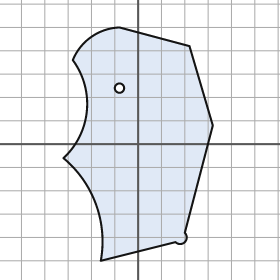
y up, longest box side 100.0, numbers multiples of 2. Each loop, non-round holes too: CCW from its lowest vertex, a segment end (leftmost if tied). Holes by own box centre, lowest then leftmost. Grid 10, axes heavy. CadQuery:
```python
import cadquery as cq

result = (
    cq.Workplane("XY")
    .moveTo(-16.0, -50.0)
    .lineTo(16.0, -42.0)
    .threePointArc((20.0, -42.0), (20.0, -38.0))
    .lineTo(32.0, 8.0)
    .lineTo(22.0, 42.0)
    .lineTo(-8.0, 50.0)
    .threePointArc((-20.0, 46.0), (-28.0, 36.0))
    .threePointArc((-22.0, 14.0), (-32.0, -6.0))
    .threePointArc((-18.0, -26.0), (-16.0, -50.0))
    .close()
    .moveTo(-8.0, 24.0)
    .circle(2.0)
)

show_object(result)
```